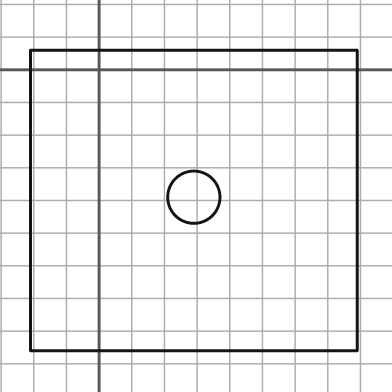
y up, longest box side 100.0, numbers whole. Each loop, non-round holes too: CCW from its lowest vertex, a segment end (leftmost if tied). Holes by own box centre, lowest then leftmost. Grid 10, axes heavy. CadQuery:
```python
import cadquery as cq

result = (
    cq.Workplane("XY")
    .moveTo(-21.0, -86.0)
    .lineTo(79.0, -86.0)
    .lineTo(79.0, 6.0)
    .lineTo(-21.0, 6.0)
    .close()
    .moveTo(29.0, -39.0)
    .circle(8.0)
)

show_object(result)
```